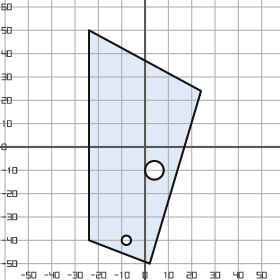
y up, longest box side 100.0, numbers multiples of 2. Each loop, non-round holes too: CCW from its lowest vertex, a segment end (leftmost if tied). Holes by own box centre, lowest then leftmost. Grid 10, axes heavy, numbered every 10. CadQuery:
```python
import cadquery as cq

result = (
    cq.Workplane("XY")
    .moveTo(2.0, -50.0)
    .lineTo(24.0, 24.0)
    .lineTo(-24.0, 50.0)
    .lineTo(-24.0, -40.0)
    .close()
    .moveTo(-8.0, -40.0)
    .circle(2.0)
    .moveTo(4.0, -10.0)
    .circle(4.0)
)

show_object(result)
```